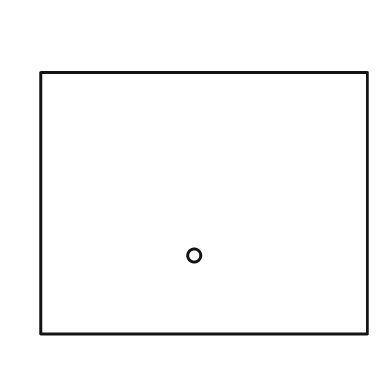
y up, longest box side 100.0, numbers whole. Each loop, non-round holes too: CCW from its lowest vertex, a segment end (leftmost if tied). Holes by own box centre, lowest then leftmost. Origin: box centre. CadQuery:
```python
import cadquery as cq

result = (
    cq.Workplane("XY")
    .moveTo(-50.0, -40.0)
    .lineTo(50.0, -40.0)
    .lineTo(50.0, 40.0)
    .lineTo(-50.0, 40.0)
    .close()
    .moveTo(-3.0, -16.0)
    .circle(2.0)
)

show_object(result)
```